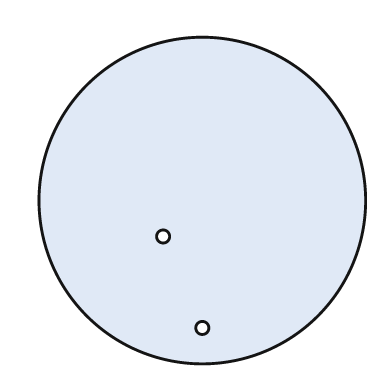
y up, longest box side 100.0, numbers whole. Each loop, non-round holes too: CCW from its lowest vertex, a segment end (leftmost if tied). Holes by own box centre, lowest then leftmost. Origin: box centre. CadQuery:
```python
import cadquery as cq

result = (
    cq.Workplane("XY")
    .moveTo(0.0, 0.0)
    .circle(50.0)
    .moveTo(0.0, -39.0)
    .circle(2.0)
    .moveTo(-12.0, -11.0)
    .circle(2.0)
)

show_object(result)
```